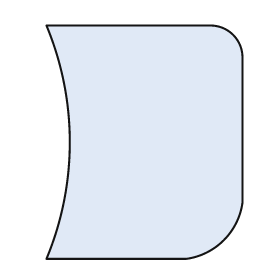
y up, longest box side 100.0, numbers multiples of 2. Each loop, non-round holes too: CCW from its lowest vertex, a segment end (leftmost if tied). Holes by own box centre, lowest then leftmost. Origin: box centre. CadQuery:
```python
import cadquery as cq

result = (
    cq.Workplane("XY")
    .moveTo(-42.0, -50.0)
    .lineTo(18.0, -50.0)
    .threePointArc((34.0, -42.0), (42.0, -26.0))
    .lineTo(42.0, 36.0)
    .threePointArc((38.0, 46.0), (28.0, 50.0))
    .lineTo(-42.0, 50.0)
    .threePointArc((-32.0, 0.0), (-42.0, -50.0))
    .close()
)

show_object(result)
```